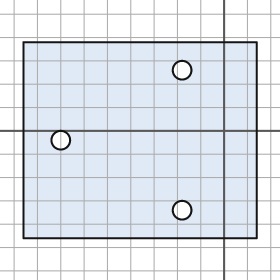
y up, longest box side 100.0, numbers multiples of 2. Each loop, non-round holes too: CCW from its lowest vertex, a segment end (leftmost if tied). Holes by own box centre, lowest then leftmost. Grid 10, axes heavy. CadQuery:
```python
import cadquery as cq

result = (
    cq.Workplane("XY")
    .moveTo(-86.0, -46.0)
    .lineTo(14.0, -46.0)
    .lineTo(14.0, 38.0)
    .lineTo(-86.0, 38.0)
    .close()
    .moveTo(-18.0, -34.0)
    .circle(4.0)
    .moveTo(-70.0, -4.0)
    .circle(4.0)
    .moveTo(-18.0, 26.0)
    .circle(4.0)
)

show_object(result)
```